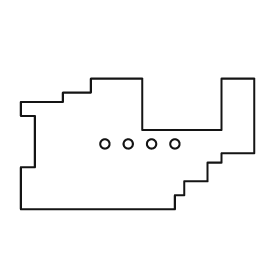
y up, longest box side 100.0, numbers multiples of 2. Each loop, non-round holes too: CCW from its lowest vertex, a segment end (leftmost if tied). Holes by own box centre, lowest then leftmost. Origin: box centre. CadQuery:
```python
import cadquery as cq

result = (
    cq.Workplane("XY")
    .moveTo(-50.0, -28.0)
    .lineTo(16.0, -28.0)
    .lineTo(16.0, -22.0)
    .lineTo(20.0, -22.0)
    .lineTo(20.0, -16.0)
    .lineTo(30.0, -16.0)
    .lineTo(30.0, -8.0)
    .lineTo(36.0, -8.0)
    .lineTo(36.0, -4.0)
    .lineTo(50.0, -4.0)
    .lineTo(50.0, 28.0)
    .lineTo(36.0, 28.0)
    .lineTo(36.0, 6.0)
    .lineTo(2.0, 6.0)
    .lineTo(2.0, 28.0)
    .lineTo(-20.0, 28.0)
    .lineTo(-20.0, 22.0)
    .lineTo(-32.0, 22.0)
    .lineTo(-32.0, 18.0)
    .lineTo(-50.0, 18.0)
    .lineTo(-50.0, 12.0)
    .lineTo(-44.0, 12.0)
    .lineTo(-44.0, -10.0)
    .lineTo(-50.0, -10.0)
    .close()
    .moveTo(-14.0, 0.0)
    .circle(2.0)
    .moveTo(-4.0, 0.0)
    .circle(2.0)
    .moveTo(6.0, 0.0)
    .circle(2.0)
    .moveTo(16.0, 0.0)
    .circle(2.0)
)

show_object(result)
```